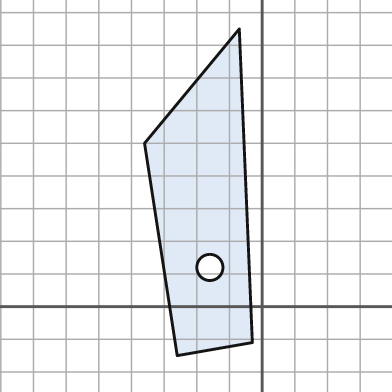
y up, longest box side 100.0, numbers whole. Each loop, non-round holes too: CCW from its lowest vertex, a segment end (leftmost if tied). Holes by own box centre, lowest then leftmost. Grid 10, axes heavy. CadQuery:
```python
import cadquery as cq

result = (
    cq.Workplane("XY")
    .moveTo(-26.0, -15.0)
    .lineTo(-3.0, -11.0)
    .lineTo(-7.0, 85.0)
    .lineTo(-36.0, 50.0)
    .close()
    .moveTo(-16.0, 12.0)
    .circle(4.0)
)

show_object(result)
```